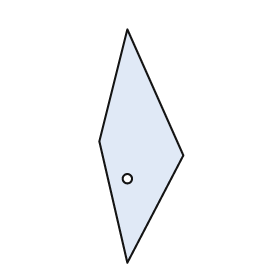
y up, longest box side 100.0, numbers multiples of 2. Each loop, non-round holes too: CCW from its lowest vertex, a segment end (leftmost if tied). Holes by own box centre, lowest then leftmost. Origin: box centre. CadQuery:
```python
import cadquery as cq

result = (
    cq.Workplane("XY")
    .moveTo(-6.0, -50.0)
    .lineTo(18.0, -4.0)
    .lineTo(-6.0, 50.0)
    .lineTo(-18.0, 2.0)
    .close()
    .moveTo(-6.0, -14.0)
    .circle(2.0)
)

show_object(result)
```